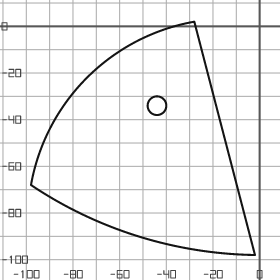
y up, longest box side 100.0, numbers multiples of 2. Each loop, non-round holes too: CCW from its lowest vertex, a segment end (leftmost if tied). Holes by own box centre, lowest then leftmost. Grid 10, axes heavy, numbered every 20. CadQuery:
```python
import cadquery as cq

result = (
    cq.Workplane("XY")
    .moveTo(-2.0, -98.0)
    .lineTo(-28.0, 2.0)
    .threePointArc((-74.0, -22.0), (-98.0, -68.0))
    .threePointArc((-52.0, -90.0), (-2.0, -98.0))
    .close()
    .moveTo(-44.0, -34.0)
    .circle(4.0)
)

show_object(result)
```